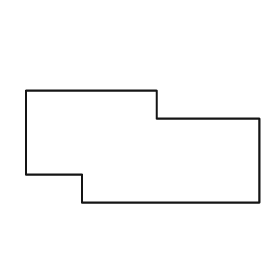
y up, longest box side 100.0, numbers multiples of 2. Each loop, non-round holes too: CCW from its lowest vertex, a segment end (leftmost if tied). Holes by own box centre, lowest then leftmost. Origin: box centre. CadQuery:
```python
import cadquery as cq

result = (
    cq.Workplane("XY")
    .moveTo(-26.0, -24.0)
    .lineTo(50.0, -24.0)
    .lineTo(50.0, 12.0)
    .lineTo(6.0, 12.0)
    .lineTo(6.0, 24.0)
    .lineTo(-50.0, 24.0)
    .lineTo(-50.0, -12.0)
    .lineTo(-26.0, -12.0)
    .close()
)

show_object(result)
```